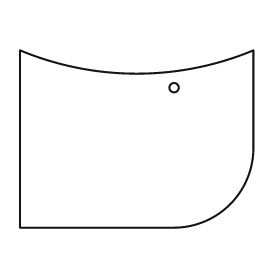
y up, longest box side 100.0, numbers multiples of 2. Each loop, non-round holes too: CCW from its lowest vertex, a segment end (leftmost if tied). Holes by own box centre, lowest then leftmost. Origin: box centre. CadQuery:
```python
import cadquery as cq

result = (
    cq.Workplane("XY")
    .moveTo(-50.0, -38.0)
    .lineTo(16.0, -38.0)
    .threePointArc((40.0, -28.0), (50.0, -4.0))
    .lineTo(50.0, 38.0)
    .threePointArc((0.0, 28.0), (-50.0, 38.0))
    .close()
    .moveTo(16.0, 22.0)
    .circle(2.0)
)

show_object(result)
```